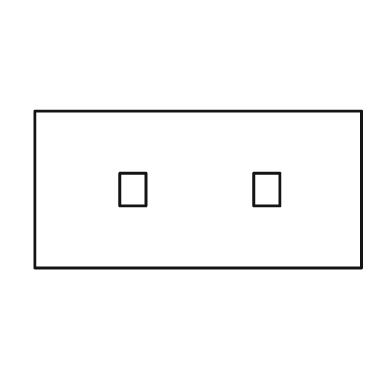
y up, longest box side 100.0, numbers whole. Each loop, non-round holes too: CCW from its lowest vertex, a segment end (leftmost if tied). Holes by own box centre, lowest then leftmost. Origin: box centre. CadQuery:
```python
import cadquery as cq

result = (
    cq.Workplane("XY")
    .moveTo(-50.0, -24.0)
    .lineTo(50.0, -24.0)
    .lineTo(50.0, 24.0)
    .lineTo(-50.0, 24.0)
    .close()
    .moveTo(-24.0, -5.0)
    .lineTo(-16.0, -5.0)
    .lineTo(-16.0, 5.0)
    .lineTo(-24.0, 5.0)
    .close()
    .moveTo(17.0, -5.0)
    .lineTo(25.0, -5.0)
    .lineTo(25.0, 5.0)
    .lineTo(17.0, 5.0)
    .close()
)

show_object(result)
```